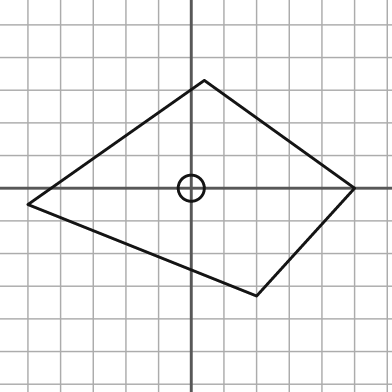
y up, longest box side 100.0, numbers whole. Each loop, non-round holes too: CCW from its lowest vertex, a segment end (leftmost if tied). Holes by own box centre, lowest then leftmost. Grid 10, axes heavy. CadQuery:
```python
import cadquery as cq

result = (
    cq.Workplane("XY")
    .moveTo(20.0, -33.0)
    .lineTo(50.0, 0.0)
    .lineTo(4.0, 33.0)
    .lineTo(-50.0, -5.0)
    .close()
    .moveTo(0.0, 0.0)
    .circle(4.0)
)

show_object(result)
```